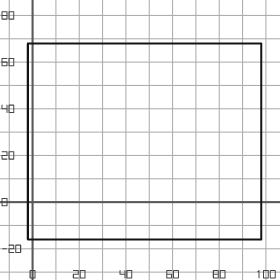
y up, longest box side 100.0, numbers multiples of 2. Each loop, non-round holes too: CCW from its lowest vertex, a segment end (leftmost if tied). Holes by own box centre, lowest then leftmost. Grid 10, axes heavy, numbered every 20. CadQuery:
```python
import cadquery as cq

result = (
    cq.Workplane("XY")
    .moveTo(-2.0, -16.0)
    .lineTo(98.0, -16.0)
    .lineTo(98.0, 68.0)
    .lineTo(-2.0, 68.0)
    .close()
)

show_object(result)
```